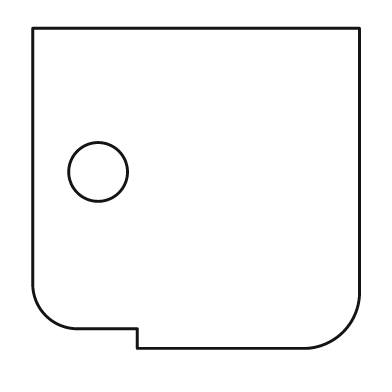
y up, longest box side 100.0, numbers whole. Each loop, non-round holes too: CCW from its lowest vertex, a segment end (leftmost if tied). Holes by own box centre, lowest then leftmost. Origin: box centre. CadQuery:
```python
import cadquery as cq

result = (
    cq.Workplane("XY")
    .moveTo(-18.0, -49.0)
    .lineTo(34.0, -49.0)
    .threePointArc((45.0, -44.0), (50.0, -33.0))
    .lineTo(50.0, 49.0)
    .lineTo(-50.0, 49.0)
    .lineTo(-50.0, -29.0)
    .threePointArc((-46.0, -39.0), (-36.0, -43.0))
    .lineTo(-18.0, -43.0)
    .close()
    .moveTo(-30.0, 5.0)
    .circle(9.0)
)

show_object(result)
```